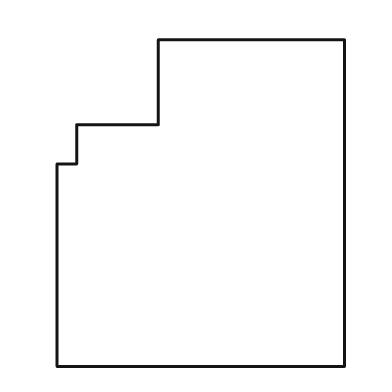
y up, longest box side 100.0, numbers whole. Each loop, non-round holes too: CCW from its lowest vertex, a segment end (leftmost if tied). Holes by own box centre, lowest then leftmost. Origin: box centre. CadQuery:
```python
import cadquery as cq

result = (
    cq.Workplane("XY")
    .moveTo(-44.0, -50.0)
    .lineTo(44.0, -50.0)
    .lineTo(44.0, 50.0)
    .lineTo(-13.0, 50.0)
    .lineTo(-13.0, 24.0)
    .lineTo(-38.0, 24.0)
    .lineTo(-38.0, 12.0)
    .lineTo(-44.0, 12.0)
    .close()
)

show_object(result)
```